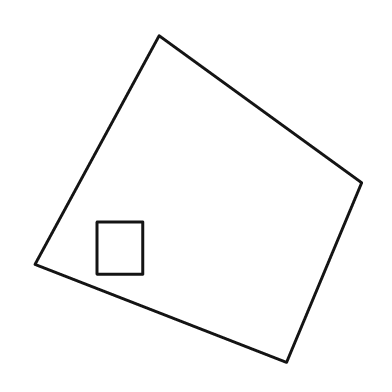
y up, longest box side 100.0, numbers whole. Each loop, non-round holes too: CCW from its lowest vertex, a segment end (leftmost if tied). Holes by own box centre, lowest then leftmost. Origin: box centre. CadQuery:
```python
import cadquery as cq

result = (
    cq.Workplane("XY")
    .moveTo(27.0, -50.0)
    .lineTo(50.0, 5.0)
    .lineTo(-12.0, 50.0)
    .lineTo(-50.0, -20.0)
    .close()
    .moveTo(-31.0, -23.0)
    .lineTo(-17.0, -23.0)
    .lineTo(-17.0, -7.0)
    .lineTo(-31.0, -7.0)
    .close()
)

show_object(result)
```